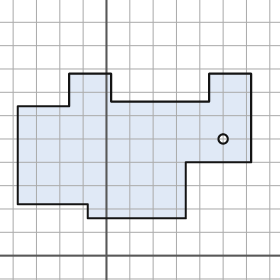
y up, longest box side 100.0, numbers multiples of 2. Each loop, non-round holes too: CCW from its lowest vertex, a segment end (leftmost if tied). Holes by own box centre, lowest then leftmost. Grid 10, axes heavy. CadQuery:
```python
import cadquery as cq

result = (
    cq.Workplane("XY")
    .moveTo(-8.0, 16.0)
    .lineTo(34.0, 16.0)
    .lineTo(34.0, 40.0)
    .lineTo(62.0, 40.0)
    .lineTo(62.0, 78.0)
    .lineTo(44.0, 78.0)
    .lineTo(44.0, 66.0)
    .lineTo(2.0, 66.0)
    .lineTo(2.0, 78.0)
    .lineTo(-16.0, 78.0)
    .lineTo(-16.0, 64.0)
    .lineTo(-38.0, 64.0)
    .lineTo(-38.0, 22.0)
    .lineTo(-8.0, 22.0)
    .close()
    .moveTo(50.0, 50.0)
    .circle(2.0)
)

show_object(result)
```